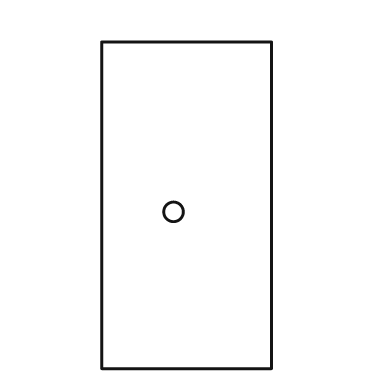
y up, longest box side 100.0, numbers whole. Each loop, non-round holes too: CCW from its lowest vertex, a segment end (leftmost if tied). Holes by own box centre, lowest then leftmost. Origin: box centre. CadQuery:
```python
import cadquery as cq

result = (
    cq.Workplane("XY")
    .moveTo(-26.0, -50.0)
    .lineTo(26.0, -50.0)
    .lineTo(26.0, 50.0)
    .lineTo(-26.0, 50.0)
    .close()
    .moveTo(-4.0, -2.0)
    .circle(3.0)
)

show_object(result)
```